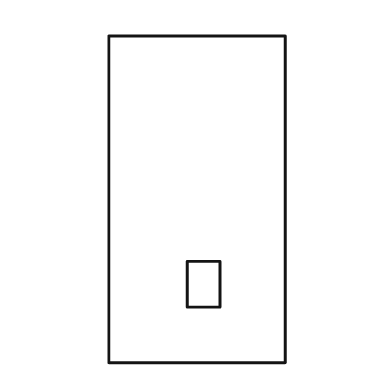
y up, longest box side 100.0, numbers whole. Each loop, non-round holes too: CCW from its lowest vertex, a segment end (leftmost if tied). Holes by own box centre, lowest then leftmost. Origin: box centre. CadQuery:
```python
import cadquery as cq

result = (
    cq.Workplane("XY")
    .moveTo(-27.0, -50.0)
    .lineTo(27.0, -50.0)
    .lineTo(27.0, 50.0)
    .lineTo(-27.0, 50.0)
    .close()
    .moveTo(-3.0, -33.0)
    .lineTo(7.0, -33.0)
    .lineTo(7.0, -19.0)
    .lineTo(-3.0, -19.0)
    .close()
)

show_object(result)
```